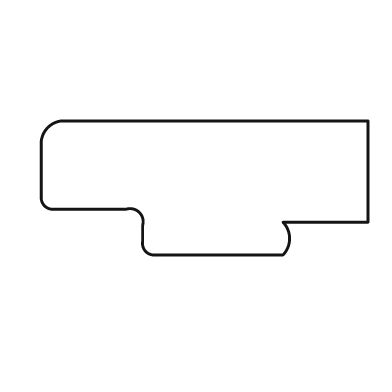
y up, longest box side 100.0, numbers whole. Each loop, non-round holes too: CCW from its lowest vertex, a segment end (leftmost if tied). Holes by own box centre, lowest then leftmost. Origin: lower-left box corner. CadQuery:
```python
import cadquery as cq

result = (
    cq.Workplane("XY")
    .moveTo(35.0, 0.0)
    .lineTo(74.0, 0.0)
    .threePointArc((76.0, 5.0), (74.0, 10.0))
    .lineTo(100.0, 10.0)
    .lineTo(100.0, 41.0)
    .lineTo(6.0, 41.0)
    .threePointArc((2.0, 39.0), (0.0, 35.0))
    .lineTo(0.0, 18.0)
    .threePointArc((1.0, 15.0), (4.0, 14.0))
    .lineTo(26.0, 14.0)
    .threePointArc((30.0, 13.0), (31.0, 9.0))
    .lineTo(31.0, 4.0)
    .threePointArc((32.0, 1.0), (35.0, 0.0))
    .close()
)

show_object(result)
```